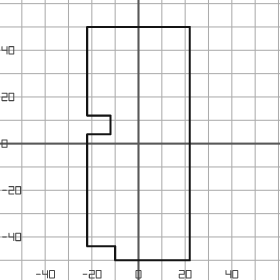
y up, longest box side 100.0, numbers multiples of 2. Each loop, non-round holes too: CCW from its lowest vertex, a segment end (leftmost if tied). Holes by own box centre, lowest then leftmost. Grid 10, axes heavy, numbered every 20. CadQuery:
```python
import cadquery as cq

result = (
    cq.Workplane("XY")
    .moveTo(-10.0, -50.0)
    .lineTo(22.0, -50.0)
    .lineTo(22.0, 50.0)
    .lineTo(-22.0, 50.0)
    .lineTo(-22.0, 12.0)
    .lineTo(-12.0, 12.0)
    .lineTo(-12.0, 4.0)
    .lineTo(-22.0, 4.0)
    .lineTo(-22.0, -44.0)
    .lineTo(-10.0, -44.0)
    .close()
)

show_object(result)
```